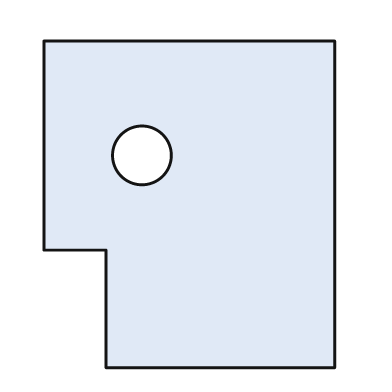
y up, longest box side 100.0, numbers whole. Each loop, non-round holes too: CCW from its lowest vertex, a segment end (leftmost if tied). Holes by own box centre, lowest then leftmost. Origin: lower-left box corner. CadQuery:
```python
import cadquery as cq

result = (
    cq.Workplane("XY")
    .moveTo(19.0, 0.0)
    .lineTo(89.0, 0.0)
    .lineTo(89.0, 100.0)
    .lineTo(0.0, 100.0)
    .lineTo(0.0, 36.0)
    .lineTo(19.0, 36.0)
    .close()
    .moveTo(30.0, 65.0)
    .circle(9.0)
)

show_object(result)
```